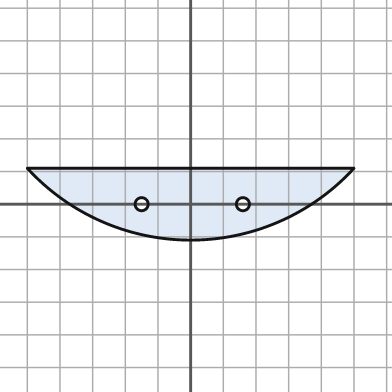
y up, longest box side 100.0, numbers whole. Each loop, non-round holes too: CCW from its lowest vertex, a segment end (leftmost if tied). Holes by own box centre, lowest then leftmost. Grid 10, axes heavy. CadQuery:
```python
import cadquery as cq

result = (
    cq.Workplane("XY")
    .moveTo(-50.0, 11.0)
    .threePointArc((0.0, -11.0), (50.0, 11.0))
    .close()
    .moveTo(-15.0, 0.0)
    .circle(2.0)
    .moveTo(16.0, 0.0)
    .circle(2.0)
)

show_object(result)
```